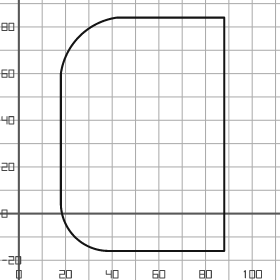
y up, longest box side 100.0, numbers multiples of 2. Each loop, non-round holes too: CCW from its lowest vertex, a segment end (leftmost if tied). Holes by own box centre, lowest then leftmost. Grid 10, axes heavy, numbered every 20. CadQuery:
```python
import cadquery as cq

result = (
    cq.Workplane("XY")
    .moveTo(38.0, -16.0)
    .lineTo(88.0, -16.0)
    .lineTo(88.0, 84.0)
    .lineTo(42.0, 84.0)
    .threePointArc((26.0, 76.0), (18.0, 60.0))
    .lineTo(18.0, 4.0)
    .threePointArc((24.0, -10.0), (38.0, -16.0))
    .close()
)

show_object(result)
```